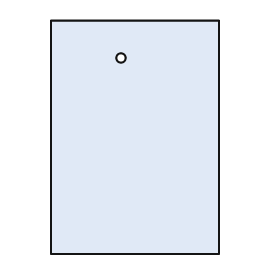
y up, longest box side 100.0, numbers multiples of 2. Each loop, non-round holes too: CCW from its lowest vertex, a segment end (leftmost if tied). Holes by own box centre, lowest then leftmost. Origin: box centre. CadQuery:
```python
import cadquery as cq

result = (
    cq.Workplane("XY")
    .moveTo(-36.0, -50.0)
    .lineTo(36.0, -50.0)
    .lineTo(36.0, 50.0)
    .lineTo(-36.0, 50.0)
    .close()
    .moveTo(-6.0, 34.0)
    .circle(2.0)
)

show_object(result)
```